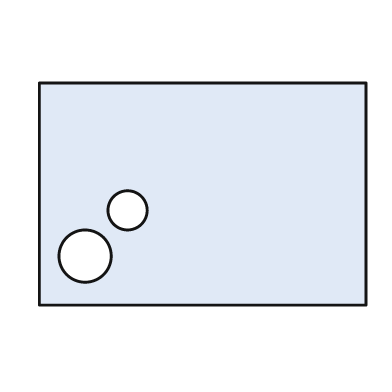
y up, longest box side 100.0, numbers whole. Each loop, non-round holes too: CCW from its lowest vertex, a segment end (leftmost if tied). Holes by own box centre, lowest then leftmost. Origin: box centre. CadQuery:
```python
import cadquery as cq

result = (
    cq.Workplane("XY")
    .moveTo(-50.0, -34.0)
    .lineTo(50.0, -34.0)
    .lineTo(50.0, 34.0)
    .lineTo(-50.0, 34.0)
    .close()
    .moveTo(-36.0, -19.0)
    .circle(8.0)
    .moveTo(-23.0, -5.0)
    .circle(6.0)
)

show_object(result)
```